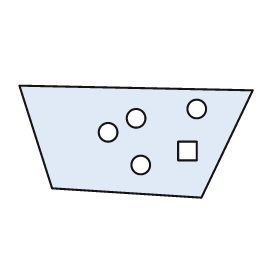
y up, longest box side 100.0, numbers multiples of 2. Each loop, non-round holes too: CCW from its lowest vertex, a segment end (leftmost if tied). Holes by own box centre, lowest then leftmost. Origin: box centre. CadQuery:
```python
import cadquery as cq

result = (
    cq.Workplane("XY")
    .moveTo(28.0, -24.0)
    .lineTo(50.0, 22.0)
    .lineTo(-50.0, 24.0)
    .lineTo(-36.0, -20.0)
    .close()
    .moveTo(2.0, -10.0)
    .circle(4.0)
    .moveTo(18.0, -8.0)
    .lineTo(26.0, -8.0)
    .lineTo(26.0, 0.0)
    .lineTo(18.0, 0.0)
    .close()
    .moveTo(-12.0, 4.0)
    .circle(4.0)
    .moveTo(0.0, 10.0)
    .circle(4.0)
    .moveTo(26.0, 14.0)
    .circle(4.0)
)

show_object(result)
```